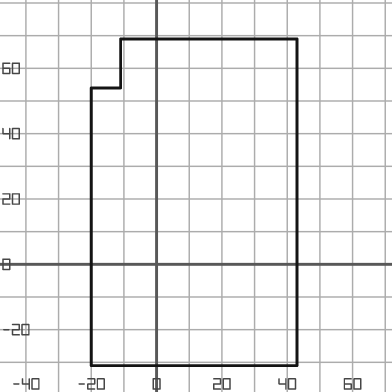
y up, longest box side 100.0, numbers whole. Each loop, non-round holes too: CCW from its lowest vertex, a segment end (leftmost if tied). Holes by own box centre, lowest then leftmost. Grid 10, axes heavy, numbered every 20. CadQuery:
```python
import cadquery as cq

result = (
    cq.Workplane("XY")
    .moveTo(-20.0, -31.0)
    .lineTo(43.0, -31.0)
    .lineTo(43.0, 69.0)
    .lineTo(-11.0, 69.0)
    .lineTo(-11.0, 54.0)
    .lineTo(-20.0, 54.0)
    .close()
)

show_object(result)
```